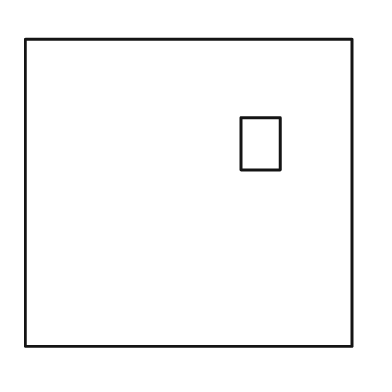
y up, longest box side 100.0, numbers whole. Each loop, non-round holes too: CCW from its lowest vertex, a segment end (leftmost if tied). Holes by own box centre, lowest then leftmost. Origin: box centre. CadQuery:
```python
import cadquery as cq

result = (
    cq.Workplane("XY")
    .moveTo(-50.0, -47.0)
    .lineTo(50.0, -47.0)
    .lineTo(50.0, 47.0)
    .lineTo(-50.0, 47.0)
    .close()
    .moveTo(16.0, 7.0)
    .lineTo(28.0, 7.0)
    .lineTo(28.0, 23.0)
    .lineTo(16.0, 23.0)
    .close()
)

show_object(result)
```